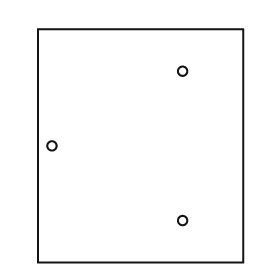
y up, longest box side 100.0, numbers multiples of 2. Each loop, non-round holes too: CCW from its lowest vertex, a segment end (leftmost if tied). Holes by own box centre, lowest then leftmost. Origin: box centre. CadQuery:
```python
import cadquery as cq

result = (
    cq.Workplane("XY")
    .moveTo(-44.0, -50.0)
    .lineTo(44.0, -50.0)
    .lineTo(44.0, 50.0)
    .lineTo(-44.0, 50.0)
    .close()
    .moveTo(18.0, -32.0)
    .circle(2.0)
    .moveTo(-38.0, 0.0)
    .circle(2.0)
    .moveTo(18.0, 32.0)
    .circle(2.0)
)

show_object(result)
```